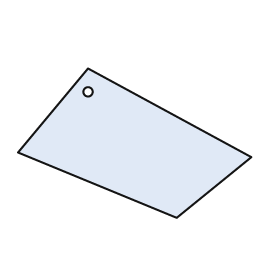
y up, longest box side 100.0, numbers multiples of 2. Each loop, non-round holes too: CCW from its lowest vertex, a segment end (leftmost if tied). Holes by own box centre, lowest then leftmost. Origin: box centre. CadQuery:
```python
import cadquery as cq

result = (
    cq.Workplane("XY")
    .moveTo(18.0, -32.0)
    .lineTo(50.0, -6.0)
    .lineTo(-20.0, 32.0)
    .lineTo(-50.0, -4.0)
    .close()
    .moveTo(-20.0, 22.0)
    .circle(2.0)
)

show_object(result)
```